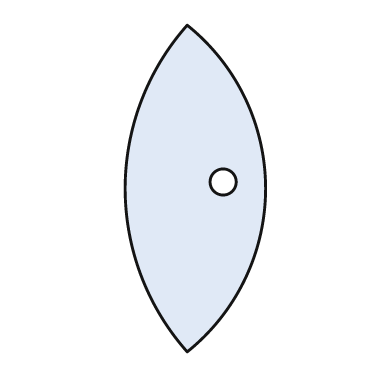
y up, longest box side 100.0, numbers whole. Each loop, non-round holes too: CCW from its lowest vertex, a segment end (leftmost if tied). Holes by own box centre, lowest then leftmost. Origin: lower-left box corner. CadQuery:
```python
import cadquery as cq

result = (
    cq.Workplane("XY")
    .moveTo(19.0, 0.0)
    .threePointArc((43.0, 50.0), (19.0, 100.0))
    .threePointArc((0.0, 50.0), (19.0, 0.0))
    .close()
    .moveTo(30.0, 52.0)
    .circle(4.0)
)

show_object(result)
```